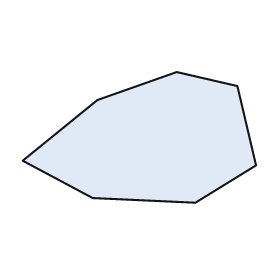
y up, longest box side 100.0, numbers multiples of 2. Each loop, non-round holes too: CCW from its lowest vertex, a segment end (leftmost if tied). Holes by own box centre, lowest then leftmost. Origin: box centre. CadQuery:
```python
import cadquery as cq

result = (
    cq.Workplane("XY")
    .moveTo(24.0, -28.0)
    .lineTo(50.0, -12.0)
    .lineTo(42.0, 22.0)
    .lineTo(16.0, 28.0)
    .lineTo(-18.0, 16.0)
    .lineTo(-50.0, -10.0)
    .lineTo(-20.0, -26.0)
    .close()
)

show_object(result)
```